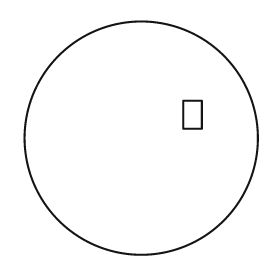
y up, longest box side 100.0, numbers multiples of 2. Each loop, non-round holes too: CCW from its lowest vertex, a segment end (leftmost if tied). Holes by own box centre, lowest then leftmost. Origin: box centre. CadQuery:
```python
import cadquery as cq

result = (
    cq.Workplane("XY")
    .moveTo(0.0, 0.0)
    .circle(50.0)
    .moveTo(18.0, 4.0)
    .lineTo(26.0, 4.0)
    .lineTo(26.0, 16.0)
    .lineTo(18.0, 16.0)
    .close()
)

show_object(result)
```